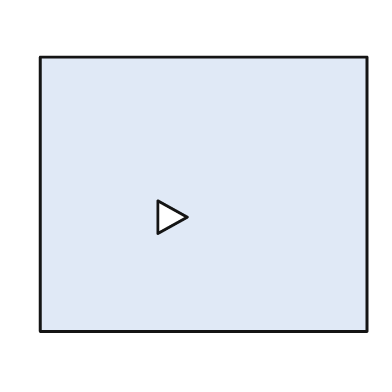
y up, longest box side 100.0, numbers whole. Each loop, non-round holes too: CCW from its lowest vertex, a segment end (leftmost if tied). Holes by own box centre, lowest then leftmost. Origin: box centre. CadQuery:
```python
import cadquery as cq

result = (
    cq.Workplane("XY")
    .moveTo(-50.0, -42.0)
    .lineTo(50.0, -42.0)
    .lineTo(50.0, 42.0)
    .lineTo(-50.0, 42.0)
    .close()
    .moveTo(-14.0, -12.0)
    .lineTo(-5.0, -7.0)
    .lineTo(-14.0, -2.0)
    .close()
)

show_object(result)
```